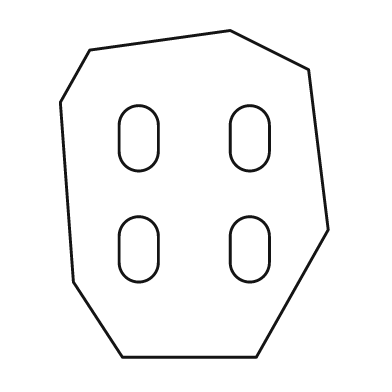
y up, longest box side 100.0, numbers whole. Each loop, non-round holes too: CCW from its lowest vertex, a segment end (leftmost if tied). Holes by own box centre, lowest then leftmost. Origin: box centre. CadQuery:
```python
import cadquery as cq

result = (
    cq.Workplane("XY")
    .moveTo(-22.0, -50.0)
    .lineTo(19.0, -50.0)
    .lineTo(41.0, -11.0)
    .lineTo(35.0, 38.0)
    .lineTo(11.0, 50.0)
    .lineTo(-32.0, 44.0)
    .lineTo(-41.0, 28.0)
    .lineTo(-37.0, -27.0)
    .close()
    .moveTo(-23.0, -21.0)
    .threePointArc((-17.0, -27.0), (-11.0, -21.0))
    .lineTo(-11.0, -13.0)
    .threePointArc((-17.0, -7.0), (-23.0, -13.0))
    .close()
    .moveTo(11.0, -21.0)
    .threePointArc((17.0, -27.0), (23.0, -21.0))
    .lineTo(23.0, -13.0)
    .threePointArc((17.0, -7.0), (11.0, -13.0))
    .close()
    .moveTo(-23.0, 13.0)
    .threePointArc((-17.0, 7.0), (-11.0, 13.0))
    .lineTo(-11.0, 21.0)
    .threePointArc((-17.0, 27.0), (-23.0, 21.0))
    .close()
    .moveTo(11.0, 13.0)
    .threePointArc((17.0, 7.0), (23.0, 13.0))
    .lineTo(23.0, 21.0)
    .threePointArc((17.0, 27.0), (11.0, 21.0))
    .close()
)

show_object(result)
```